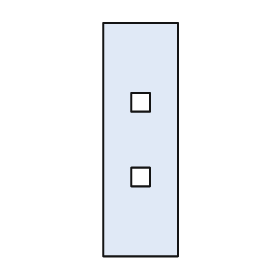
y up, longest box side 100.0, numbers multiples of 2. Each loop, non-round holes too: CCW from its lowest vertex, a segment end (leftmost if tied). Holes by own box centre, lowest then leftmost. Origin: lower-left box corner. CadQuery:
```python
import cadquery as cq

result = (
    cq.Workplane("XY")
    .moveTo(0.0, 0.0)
    .lineTo(32.0, 0.0)
    .lineTo(32.0, 100.0)
    .lineTo(0.0, 100.0)
    .close()
    .moveTo(12.0, 30.0)
    .lineTo(20.0, 30.0)
    .lineTo(20.0, 38.0)
    .lineTo(12.0, 38.0)
    .close()
    .moveTo(12.0, 62.0)
    .lineTo(20.0, 62.0)
    .lineTo(20.0, 70.0)
    .lineTo(12.0, 70.0)
    .close()
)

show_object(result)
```